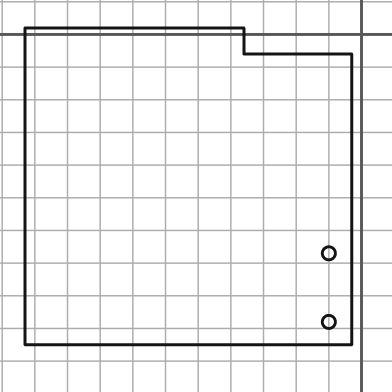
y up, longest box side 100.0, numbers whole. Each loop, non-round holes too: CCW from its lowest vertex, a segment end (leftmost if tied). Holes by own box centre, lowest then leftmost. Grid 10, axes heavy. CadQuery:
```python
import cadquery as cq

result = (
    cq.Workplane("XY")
    .moveTo(-103.0, -95.0)
    .lineTo(-3.0, -95.0)
    .lineTo(-3.0, -6.0)
    .lineTo(-36.0, -6.0)
    .lineTo(-36.0, 2.0)
    .lineTo(-103.0, 2.0)
    .close()
    .moveTo(-10.0, -88.0)
    .circle(2.0)
    .moveTo(-10.0, -67.0)
    .circle(2.0)
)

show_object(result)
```